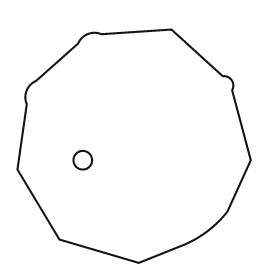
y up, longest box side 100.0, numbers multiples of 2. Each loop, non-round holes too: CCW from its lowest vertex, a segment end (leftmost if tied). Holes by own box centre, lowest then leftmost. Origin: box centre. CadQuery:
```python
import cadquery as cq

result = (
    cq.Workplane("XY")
    .moveTo(2.0, -50.0)
    .lineTo(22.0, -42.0)
    .threePointArc((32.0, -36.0), (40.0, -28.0))
    .lineTo(50.0, -6.0)
    .lineTo(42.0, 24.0)
    .threePointArc((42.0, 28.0), (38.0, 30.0))
    .lineTo(16.0, 50.0)
    .lineTo(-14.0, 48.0)
    .threePointArc((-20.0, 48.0), (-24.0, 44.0))
    .lineTo(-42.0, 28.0)
    .threePointArc((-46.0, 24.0), (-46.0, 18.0))
    .lineTo(-50.0, -10.0)
    .lineTo(-32.0, -40.0)
    .close()
    .moveTo(-22.0, -6.0)
    .circle(4.0)
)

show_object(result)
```